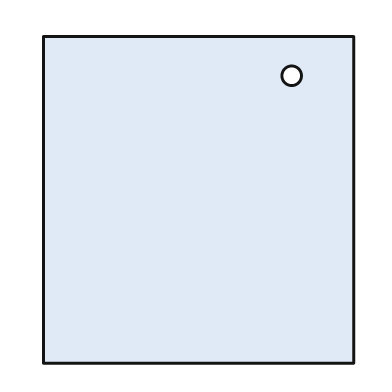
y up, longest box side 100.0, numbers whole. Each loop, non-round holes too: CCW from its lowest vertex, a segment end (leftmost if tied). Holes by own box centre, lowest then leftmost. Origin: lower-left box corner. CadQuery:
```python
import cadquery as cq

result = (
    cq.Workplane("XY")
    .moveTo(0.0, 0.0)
    .lineTo(95.0, 0.0)
    .lineTo(95.0, 100.0)
    .lineTo(0.0, 100.0)
    .close()
    .moveTo(76.0, 88.0)
    .circle(3.0)
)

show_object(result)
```